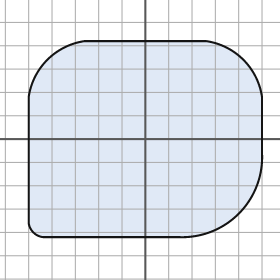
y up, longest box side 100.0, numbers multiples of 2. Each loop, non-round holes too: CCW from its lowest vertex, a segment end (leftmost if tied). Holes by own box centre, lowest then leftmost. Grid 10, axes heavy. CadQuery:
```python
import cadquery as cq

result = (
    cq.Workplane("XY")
    .moveTo(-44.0, -42.0)
    .lineTo(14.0, -42.0)
    .threePointArc((40.0, -32.0), (50.0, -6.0))
    .lineTo(50.0, 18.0)
    .threePointArc((42.0, 34.0), (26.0, 42.0))
    .lineTo(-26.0, 42.0)
    .threePointArc((-42.0, 34.0), (-50.0, 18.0))
    .lineTo(-50.0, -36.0)
    .threePointArc((-48.0, -40.0), (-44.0, -42.0))
    .close()
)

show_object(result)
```